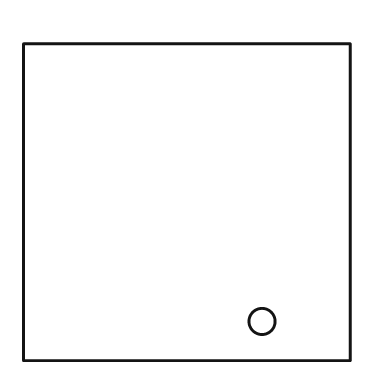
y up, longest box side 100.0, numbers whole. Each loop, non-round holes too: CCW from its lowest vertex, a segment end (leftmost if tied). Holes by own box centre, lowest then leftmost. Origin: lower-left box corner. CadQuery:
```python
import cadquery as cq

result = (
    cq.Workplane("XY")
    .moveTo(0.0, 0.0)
    .lineTo(100.0, 0.0)
    .lineTo(100.0, 97.0)
    .lineTo(0.0, 97.0)
    .close()
    .moveTo(73.0, 12.0)
    .circle(4.0)
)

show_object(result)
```